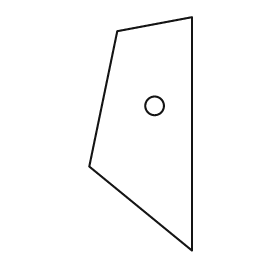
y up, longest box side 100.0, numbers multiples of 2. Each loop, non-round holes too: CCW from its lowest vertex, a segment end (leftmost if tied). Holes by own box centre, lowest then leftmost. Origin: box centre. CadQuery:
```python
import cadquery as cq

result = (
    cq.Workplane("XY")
    .moveTo(22.0, -50.0)
    .lineTo(22.0, 50.0)
    .lineTo(-10.0, 44.0)
    .lineTo(-22.0, -14.0)
    .close()
    .moveTo(6.0, 12.0)
    .circle(4.0)
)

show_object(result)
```